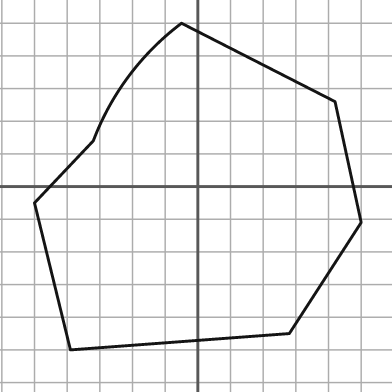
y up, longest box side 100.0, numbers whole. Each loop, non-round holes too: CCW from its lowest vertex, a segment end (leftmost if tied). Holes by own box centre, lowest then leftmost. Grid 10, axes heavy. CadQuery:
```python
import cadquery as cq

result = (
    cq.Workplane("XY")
    .moveTo(-39.0, -50.0)
    .lineTo(28.0, -45.0)
    .lineTo(50.0, -11.0)
    .lineTo(42.0, 26.0)
    .lineTo(-5.0, 50.0)
    .threePointArc((-21.0, 34.0), (-32.0, 14.0))
    .lineTo(-50.0, -5.0)
    .close()
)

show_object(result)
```